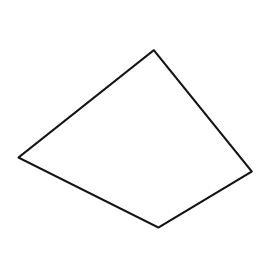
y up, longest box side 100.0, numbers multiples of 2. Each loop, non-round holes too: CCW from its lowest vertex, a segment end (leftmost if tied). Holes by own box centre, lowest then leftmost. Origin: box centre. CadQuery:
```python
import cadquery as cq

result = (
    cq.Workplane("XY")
    .moveTo(10.0, -38.0)
    .lineTo(50.0, -14.0)
    .lineTo(8.0, 38.0)
    .lineTo(-50.0, -8.0)
    .close()
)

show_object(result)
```